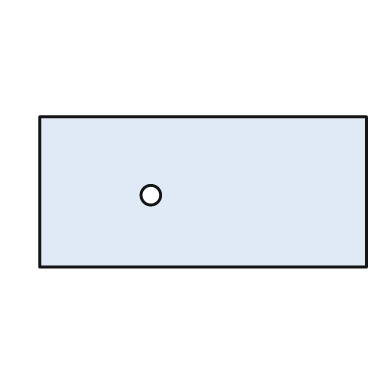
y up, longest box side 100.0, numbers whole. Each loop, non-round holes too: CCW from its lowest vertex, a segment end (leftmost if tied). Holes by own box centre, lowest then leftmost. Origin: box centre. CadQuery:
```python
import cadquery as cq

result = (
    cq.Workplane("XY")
    .moveTo(-50.0, -23.0)
    .lineTo(50.0, -23.0)
    .lineTo(50.0, 23.0)
    .lineTo(-50.0, 23.0)
    .close()
    .moveTo(-16.0, -1.0)
    .circle(3.0)
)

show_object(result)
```